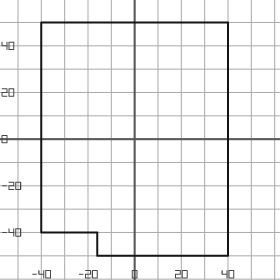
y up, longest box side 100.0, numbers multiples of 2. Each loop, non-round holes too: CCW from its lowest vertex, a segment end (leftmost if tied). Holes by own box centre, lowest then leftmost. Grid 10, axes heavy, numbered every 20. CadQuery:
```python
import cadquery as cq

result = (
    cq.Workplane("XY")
    .moveTo(-16.0, -50.0)
    .lineTo(40.0, -50.0)
    .lineTo(40.0, 50.0)
    .lineTo(-40.0, 50.0)
    .lineTo(-40.0, -40.0)
    .lineTo(-16.0, -40.0)
    .close()
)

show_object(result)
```